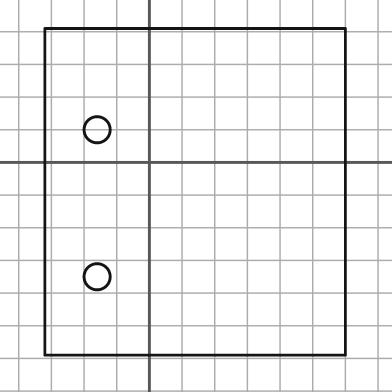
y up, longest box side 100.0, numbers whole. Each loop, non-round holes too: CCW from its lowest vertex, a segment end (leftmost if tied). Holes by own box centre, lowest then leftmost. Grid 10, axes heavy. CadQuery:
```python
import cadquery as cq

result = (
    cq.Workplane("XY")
    .moveTo(-32.0, -59.0)
    .lineTo(60.0, -59.0)
    .lineTo(60.0, 41.0)
    .lineTo(-32.0, 41.0)
    .close()
    .moveTo(-16.0, -35.0)
    .circle(4.0)
    .moveTo(-16.0, 10.0)
    .circle(4.0)
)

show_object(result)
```